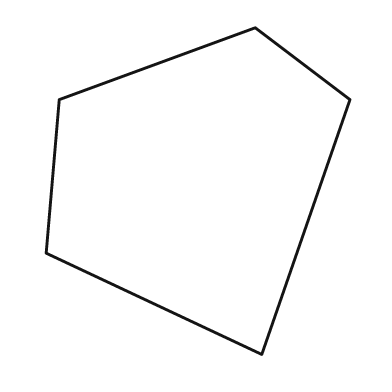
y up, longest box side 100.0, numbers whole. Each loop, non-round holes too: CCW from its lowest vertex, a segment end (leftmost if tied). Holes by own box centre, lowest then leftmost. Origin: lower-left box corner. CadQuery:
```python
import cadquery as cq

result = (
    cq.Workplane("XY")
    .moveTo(66.0, 0.0)
    .lineTo(93.0, 78.0)
    .lineTo(64.0, 100.0)
    .lineTo(4.0, 78.0)
    .lineTo(0.0, 31.0)
    .close()
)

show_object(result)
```